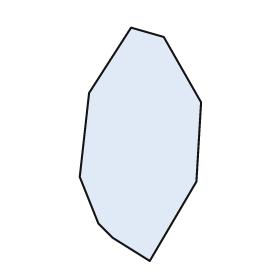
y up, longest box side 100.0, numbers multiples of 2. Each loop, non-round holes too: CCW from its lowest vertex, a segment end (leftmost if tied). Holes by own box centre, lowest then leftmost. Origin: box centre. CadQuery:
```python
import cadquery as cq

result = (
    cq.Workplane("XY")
    .moveTo(4.0, -50.0)
    .lineTo(24.0, -16.0)
    .lineTo(26.0, 18.0)
    .lineTo(10.0, 46.0)
    .lineTo(-4.0, 50.0)
    .lineTo(-22.0, 22.0)
    .lineTo(-26.0, -14.0)
    .lineTo(-18.0, -34.0)
    .lineTo(-12.0, -40.0)
    .close()
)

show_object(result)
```